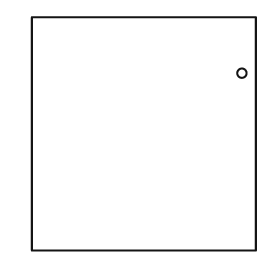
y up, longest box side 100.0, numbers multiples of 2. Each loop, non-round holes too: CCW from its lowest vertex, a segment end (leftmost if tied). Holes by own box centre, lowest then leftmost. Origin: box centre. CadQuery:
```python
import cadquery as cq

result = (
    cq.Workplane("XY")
    .moveTo(-48.0, -50.0)
    .lineTo(48.0, -50.0)
    .lineTo(48.0, 50.0)
    .lineTo(-48.0, 50.0)
    .close()
    .moveTo(42.0, 26.0)
    .circle(2.0)
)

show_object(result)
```